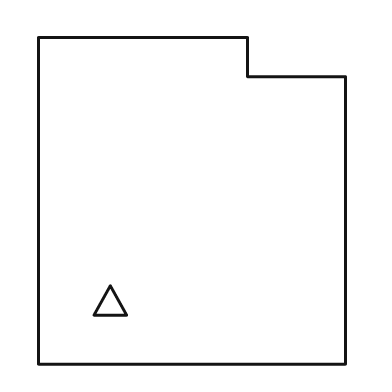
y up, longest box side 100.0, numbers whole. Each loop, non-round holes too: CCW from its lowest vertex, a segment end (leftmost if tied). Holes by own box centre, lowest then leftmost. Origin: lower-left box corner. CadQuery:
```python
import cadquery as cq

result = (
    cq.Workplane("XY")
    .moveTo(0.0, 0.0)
    .lineTo(94.0, 0.0)
    .lineTo(94.0, 88.0)
    .lineTo(64.0, 88.0)
    .lineTo(64.0, 100.0)
    .lineTo(0.0, 100.0)
    .close()
    .moveTo(17.0, 15.0)
    .lineTo(27.0, 15.0)
    .lineTo(22.0, 24.0)
    .close()
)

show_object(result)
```